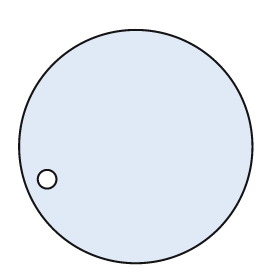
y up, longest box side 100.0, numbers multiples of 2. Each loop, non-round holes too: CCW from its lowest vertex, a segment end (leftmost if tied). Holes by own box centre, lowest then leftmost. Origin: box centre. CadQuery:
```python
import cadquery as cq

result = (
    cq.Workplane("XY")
    .moveTo(0.0, 0.0)
    .circle(50.0)
    .moveTo(-38.0, -14.0)
    .circle(4.0)
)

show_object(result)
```